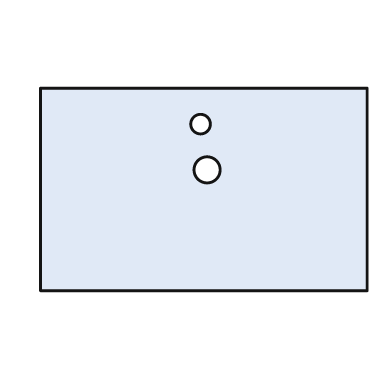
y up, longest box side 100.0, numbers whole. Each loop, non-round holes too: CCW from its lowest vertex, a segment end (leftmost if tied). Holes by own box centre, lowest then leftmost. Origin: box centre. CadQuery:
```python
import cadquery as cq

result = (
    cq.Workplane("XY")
    .moveTo(-50.0, -31.0)
    .lineTo(50.0, -31.0)
    .lineTo(50.0, 31.0)
    .lineTo(-50.0, 31.0)
    .close()
    .moveTo(1.0, 6.0)
    .circle(4.0)
    .moveTo(-1.0, 20.0)
    .circle(3.0)
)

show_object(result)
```